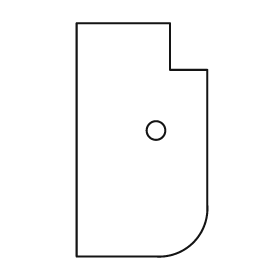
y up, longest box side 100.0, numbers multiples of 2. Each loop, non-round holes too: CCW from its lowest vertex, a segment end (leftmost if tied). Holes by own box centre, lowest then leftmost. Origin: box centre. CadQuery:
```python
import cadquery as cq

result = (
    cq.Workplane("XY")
    .moveTo(-28.0, -50.0)
    .lineTo(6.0, -50.0)
    .threePointArc((22.0, -44.0), (28.0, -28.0))
    .lineTo(28.0, 30.0)
    .lineTo(12.0, 30.0)
    .lineTo(12.0, 50.0)
    .lineTo(-28.0, 50.0)
    .close()
    .moveTo(6.0, 4.0)
    .circle(4.0)
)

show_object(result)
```